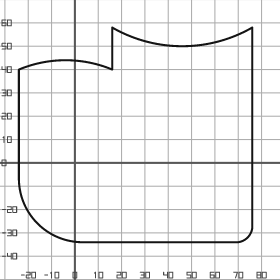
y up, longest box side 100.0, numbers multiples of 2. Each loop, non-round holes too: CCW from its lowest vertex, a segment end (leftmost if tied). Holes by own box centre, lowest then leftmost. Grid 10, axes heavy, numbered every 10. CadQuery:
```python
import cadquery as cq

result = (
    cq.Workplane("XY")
    .moveTo(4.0, -34.0)
    .lineTo(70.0, -34.0)
    .threePointArc((74.0, -32.0), (76.0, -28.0))
    .lineTo(76.0, 58.0)
    .threePointArc((46.0, 50.0), (16.0, 58.0))
    .lineTo(16.0, 40.0)
    .threePointArc((-4.0, 44.0), (-24.0, 40.0))
    .lineTo(-24.0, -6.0)
    .threePointArc((-16.0, -26.0), (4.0, -34.0))
    .close()
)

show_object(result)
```